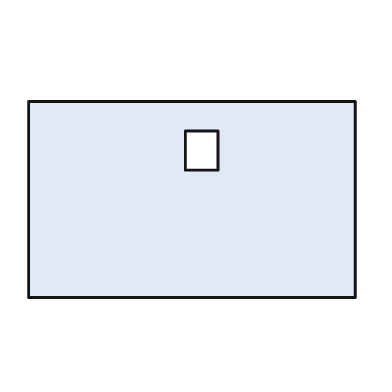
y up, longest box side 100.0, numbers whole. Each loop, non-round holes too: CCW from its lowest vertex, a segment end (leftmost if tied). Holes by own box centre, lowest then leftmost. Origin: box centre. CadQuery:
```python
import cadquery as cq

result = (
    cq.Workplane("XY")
    .moveTo(-50.0, -30.0)
    .lineTo(50.0, -30.0)
    .lineTo(50.0, 30.0)
    .lineTo(-50.0, 30.0)
    .close()
    .moveTo(-2.0, 9.0)
    .lineTo(8.0, 9.0)
    .lineTo(8.0, 21.0)
    .lineTo(-2.0, 21.0)
    .close()
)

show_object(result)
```